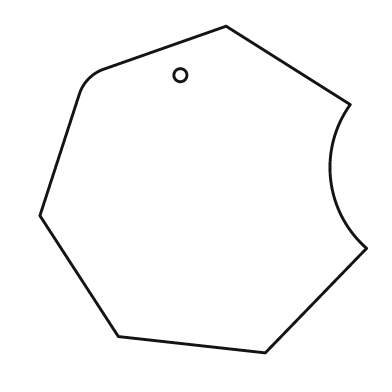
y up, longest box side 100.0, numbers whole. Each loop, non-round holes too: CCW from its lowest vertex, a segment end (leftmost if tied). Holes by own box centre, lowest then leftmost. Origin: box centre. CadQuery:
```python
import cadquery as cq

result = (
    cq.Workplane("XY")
    .moveTo(19.0, -50.0)
    .lineTo(50.0, -18.0)
    .threePointArc((39.0, 3.0), (45.0, 26.0))
    .lineTo(7.0, 50.0)
    .lineTo(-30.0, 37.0)
    .threePointArc((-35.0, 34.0), (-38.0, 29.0))
    .lineTo(-50.0, -8.0)
    .lineTo(-26.0, -45.0)
    .close()
    .moveTo(-7.0, 35.0)
    .circle(2.0)
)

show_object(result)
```